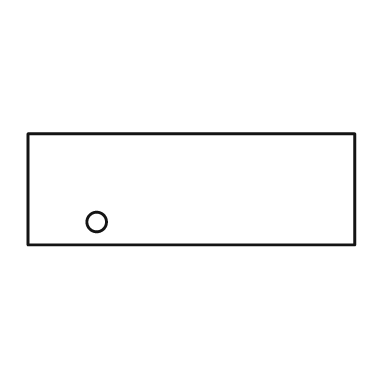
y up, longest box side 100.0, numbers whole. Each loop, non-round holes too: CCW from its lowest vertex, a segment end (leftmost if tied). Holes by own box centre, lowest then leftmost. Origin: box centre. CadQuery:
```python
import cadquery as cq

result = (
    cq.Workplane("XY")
    .moveTo(-50.0, -17.0)
    .lineTo(50.0, -17.0)
    .lineTo(50.0, 17.0)
    .lineTo(-50.0, 17.0)
    .close()
    .moveTo(-29.0, -10.0)
    .circle(3.0)
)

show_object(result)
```